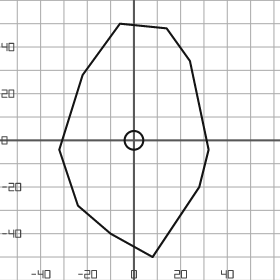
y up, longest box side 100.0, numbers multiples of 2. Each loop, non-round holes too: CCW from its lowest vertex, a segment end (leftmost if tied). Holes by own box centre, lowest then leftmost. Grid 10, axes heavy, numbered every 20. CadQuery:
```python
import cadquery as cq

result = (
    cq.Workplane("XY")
    .moveTo(8.0, -50.0)
    .lineTo(28.0, -20.0)
    .lineTo(32.0, -4.0)
    .lineTo(24.0, 34.0)
    .lineTo(14.0, 48.0)
    .lineTo(-6.0, 50.0)
    .lineTo(-22.0, 28.0)
    .lineTo(-32.0, -4.0)
    .lineTo(-24.0, -28.0)
    .lineTo(-10.0, -40.0)
    .close()
    .moveTo(0.0, 0.0)
    .circle(4.0)
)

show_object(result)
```